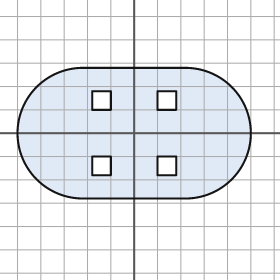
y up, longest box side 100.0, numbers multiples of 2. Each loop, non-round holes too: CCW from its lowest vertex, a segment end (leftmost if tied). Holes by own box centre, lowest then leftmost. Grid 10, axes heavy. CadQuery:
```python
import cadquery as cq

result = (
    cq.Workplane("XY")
    .moveTo(-22.0, -28.0)
    .lineTo(22.0, -28.0)
    .threePointArc((50.0, 0.0), (22.0, 28.0))
    .lineTo(-22.0, 28.0)
    .threePointArc((-50.0, 0.0), (-22.0, -28.0))
    .close()
    .moveTo(-18.0, -18.0)
    .lineTo(-10.0, -18.0)
    .lineTo(-10.0, -10.0)
    .lineTo(-18.0, -10.0)
    .close()
    .moveTo(10.0, -18.0)
    .lineTo(18.0, -18.0)
    .lineTo(18.0, -10.0)
    .lineTo(10.0, -10.0)
    .close()
    .moveTo(-18.0, 10.0)
    .lineTo(-10.0, 10.0)
    .lineTo(-10.0, 18.0)
    .lineTo(-18.0, 18.0)
    .close()
    .moveTo(10.0, 10.0)
    .lineTo(18.0, 10.0)
    .lineTo(18.0, 18.0)
    .lineTo(10.0, 18.0)
    .close()
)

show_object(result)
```